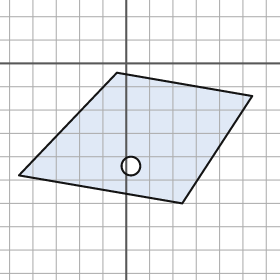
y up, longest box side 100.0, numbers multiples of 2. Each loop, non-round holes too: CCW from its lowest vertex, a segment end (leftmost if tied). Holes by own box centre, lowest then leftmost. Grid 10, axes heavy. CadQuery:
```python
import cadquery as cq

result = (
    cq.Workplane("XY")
    .moveTo(24.0, -60.0)
    .lineTo(54.0, -14.0)
    .lineTo(-4.0, -4.0)
    .lineTo(-46.0, -48.0)
    .close()
    .moveTo(2.0, -44.0)
    .circle(4.0)
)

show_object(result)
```